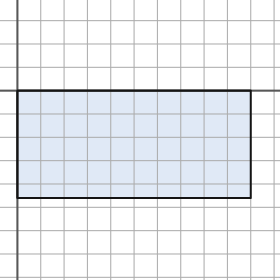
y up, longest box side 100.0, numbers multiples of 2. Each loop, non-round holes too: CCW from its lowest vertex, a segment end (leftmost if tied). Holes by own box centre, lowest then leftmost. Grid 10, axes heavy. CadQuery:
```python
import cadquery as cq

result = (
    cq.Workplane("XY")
    .moveTo(0.0, -46.0)
    .lineTo(100.0, -46.0)
    .lineTo(100.0, 0.0)
    .lineTo(0.0, 0.0)
    .close()
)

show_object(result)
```